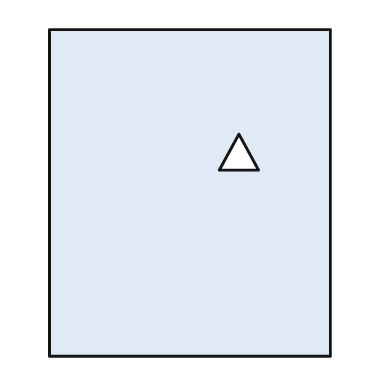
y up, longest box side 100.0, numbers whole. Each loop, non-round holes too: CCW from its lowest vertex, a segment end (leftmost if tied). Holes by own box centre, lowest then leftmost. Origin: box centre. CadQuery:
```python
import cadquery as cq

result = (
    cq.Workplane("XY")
    .moveTo(-43.0, -50.0)
    .lineTo(43.0, -50.0)
    .lineTo(43.0, 50.0)
    .lineTo(-43.0, 50.0)
    .close()
    .moveTo(9.0, 7.0)
    .lineTo(21.0, 7.0)
    .lineTo(15.0, 18.0)
    .close()
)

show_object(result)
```